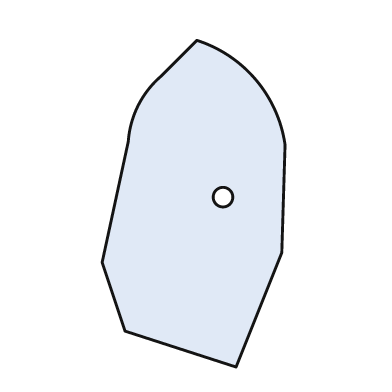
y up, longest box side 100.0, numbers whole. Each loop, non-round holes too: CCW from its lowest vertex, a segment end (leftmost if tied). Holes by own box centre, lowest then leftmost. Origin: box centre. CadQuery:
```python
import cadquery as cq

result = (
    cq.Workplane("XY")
    .moveTo(13.0, -50.0)
    .lineTo(27.0, -15.0)
    .lineTo(28.0, 18.0)
    .threePointArc((19.0, 38.0), (1.0, 50.0))
    .lineTo(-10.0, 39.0)
    .threePointArc((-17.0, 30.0), (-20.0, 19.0))
    .lineTo(-28.0, -18.0)
    .lineTo(-21.0, -39.0)
    .close()
    .moveTo(9.0, 2.0)
    .circle(3.0)
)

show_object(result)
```